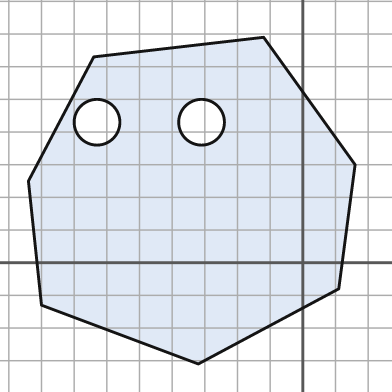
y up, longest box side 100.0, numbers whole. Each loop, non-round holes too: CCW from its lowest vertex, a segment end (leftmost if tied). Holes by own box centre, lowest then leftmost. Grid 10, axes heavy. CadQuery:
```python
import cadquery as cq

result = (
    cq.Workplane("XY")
    .moveTo(-32.0, -31.0)
    .lineTo(11.0, -8.0)
    .lineTo(16.0, 30.0)
    .lineTo(-12.0, 69.0)
    .lineTo(-64.0, 63.0)
    .lineTo(-84.0, 25.0)
    .lineTo(-80.0, -13.0)
    .close()
    .moveTo(-63.0, 43.0)
    .circle(7.0)
    .moveTo(-31.0, 43.0)
    .circle(7.0)
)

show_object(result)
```